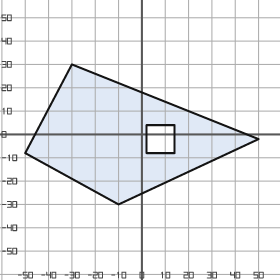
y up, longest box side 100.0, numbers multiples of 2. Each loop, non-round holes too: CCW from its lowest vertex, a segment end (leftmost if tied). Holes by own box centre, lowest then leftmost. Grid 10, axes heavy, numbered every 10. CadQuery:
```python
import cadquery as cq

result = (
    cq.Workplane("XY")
    .moveTo(-10.0, -30.0)
    .lineTo(50.0, -2.0)
    .lineTo(-30.0, 30.0)
    .lineTo(-50.0, -8.0)
    .close()
    .moveTo(2.0, -8.0)
    .lineTo(14.0, -8.0)
    .lineTo(14.0, 4.0)
    .lineTo(2.0, 4.0)
    .close()
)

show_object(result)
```